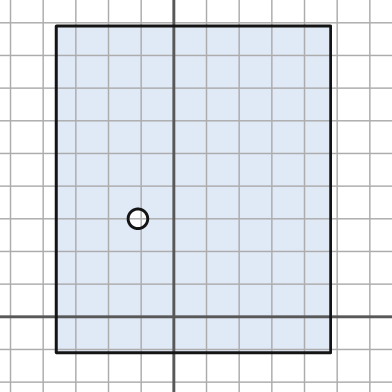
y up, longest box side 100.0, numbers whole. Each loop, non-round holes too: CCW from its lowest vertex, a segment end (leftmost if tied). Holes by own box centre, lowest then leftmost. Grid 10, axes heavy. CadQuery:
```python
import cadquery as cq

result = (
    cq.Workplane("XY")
    .moveTo(-36.0, -11.0)
    .lineTo(48.0, -11.0)
    .lineTo(48.0, 89.0)
    .lineTo(-36.0, 89.0)
    .close()
    .moveTo(-11.0, 30.0)
    .circle(3.0)
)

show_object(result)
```